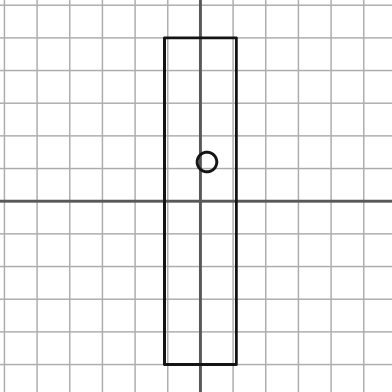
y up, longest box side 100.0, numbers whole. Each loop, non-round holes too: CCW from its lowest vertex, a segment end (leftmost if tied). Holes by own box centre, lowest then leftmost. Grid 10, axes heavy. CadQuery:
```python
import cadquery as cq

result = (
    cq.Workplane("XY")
    .moveTo(-11.0, -50.0)
    .lineTo(11.0, -50.0)
    .lineTo(11.0, 50.0)
    .lineTo(-11.0, 50.0)
    .close()
    .moveTo(2.0, 12.0)
    .circle(3.0)
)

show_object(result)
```